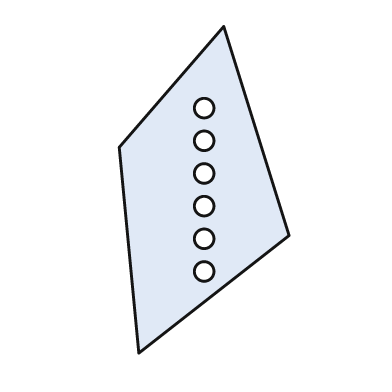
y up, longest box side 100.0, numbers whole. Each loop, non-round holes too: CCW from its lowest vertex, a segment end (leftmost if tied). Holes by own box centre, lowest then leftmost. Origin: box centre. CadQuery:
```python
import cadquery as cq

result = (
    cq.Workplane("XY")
    .moveTo(-20.0, -50.0)
    .lineTo(26.0, -14.0)
    .lineTo(6.0, 50.0)
    .lineTo(-26.0, 13.0)
    .close()
    .moveTo(0.0, -25.0)
    .circle(3.0)
    .moveTo(0.0, -15.0)
    .circle(3.0)
    .moveTo(0.0, -5.0)
    .circle(3.0)
    .moveTo(0.0, 5.0)
    .circle(3.0)
    .moveTo(0.0, 15.0)
    .circle(3.0)
    .moveTo(0.0, 25.0)
    .circle(3.0)
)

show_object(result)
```